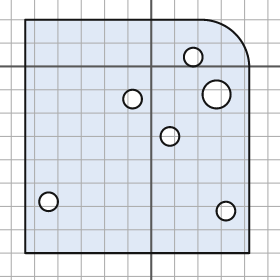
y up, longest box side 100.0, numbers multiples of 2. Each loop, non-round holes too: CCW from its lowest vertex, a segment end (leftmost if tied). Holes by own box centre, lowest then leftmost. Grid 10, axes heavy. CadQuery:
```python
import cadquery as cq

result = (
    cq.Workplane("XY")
    .moveTo(-54.0, -80.0)
    .lineTo(42.0, -80.0)
    .lineTo(42.0, 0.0)
    .threePointArc((36.0, 14.0), (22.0, 20.0))
    .lineTo(-54.0, 20.0)
    .close()
    .moveTo(32.0, -62.0)
    .circle(4.0)
    .moveTo(-44.0, -58.0)
    .circle(4.0)
    .moveTo(8.0, -30.0)
    .circle(4.0)
    .moveTo(-8.0, -14.0)
    .circle(4.0)
    .moveTo(28.0, -12.0)
    .circle(6.0)
    .moveTo(18.0, 4.0)
    .circle(4.0)
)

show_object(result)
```